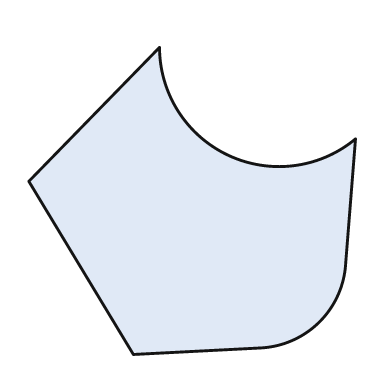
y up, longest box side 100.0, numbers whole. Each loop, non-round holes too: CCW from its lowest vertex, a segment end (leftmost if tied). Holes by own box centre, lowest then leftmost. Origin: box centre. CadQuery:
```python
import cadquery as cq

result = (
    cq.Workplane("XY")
    .moveTo(-18.0, -47.0)
    .lineTo(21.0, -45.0)
    .threePointArc((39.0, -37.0), (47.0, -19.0))
    .lineTo(50.0, 19.0)
    .threePointArc((11.0, 14.0), (-10.0, 47.0))
    .lineTo(-50.0, 6.0)
    .close()
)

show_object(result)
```